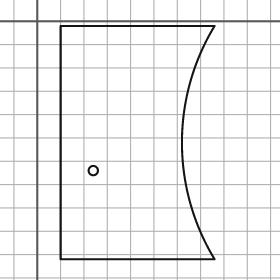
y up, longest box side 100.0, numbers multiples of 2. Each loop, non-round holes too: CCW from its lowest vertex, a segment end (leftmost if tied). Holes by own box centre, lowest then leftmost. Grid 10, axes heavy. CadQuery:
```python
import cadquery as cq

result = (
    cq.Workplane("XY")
    .moveTo(10.0, -102.0)
    .lineTo(76.0, -102.0)
    .threePointArc((62.0, -52.0), (76.0, -2.0))
    .lineTo(10.0, -2.0)
    .close()
    .moveTo(24.0, -64.0)
    .circle(2.0)
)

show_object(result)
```